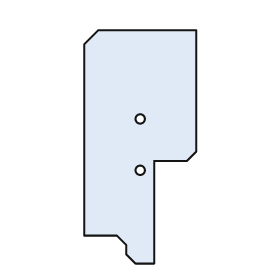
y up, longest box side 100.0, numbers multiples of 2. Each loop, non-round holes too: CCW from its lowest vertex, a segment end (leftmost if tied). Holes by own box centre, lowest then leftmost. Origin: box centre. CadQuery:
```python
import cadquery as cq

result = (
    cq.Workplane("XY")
    .moveTo(-2.0, -50.0)
    .lineTo(6.0, -50.0)
    .lineTo(6.0, -6.0)
    .lineTo(20.0, -6.0)
    .lineTo(24.0, -2.0)
    .lineTo(24.0, 50.0)
    .lineTo(-18.0, 50.0)
    .lineTo(-24.0, 44.0)
    .lineTo(-24.0, -38.0)
    .lineTo(-10.0, -38.0)
    .lineTo(-6.0, -42.0)
    .lineTo(-6.0, -46.0)
    .close()
    .moveTo(0.0, -10.0)
    .circle(2.0)
    .moveTo(0.0, 12.0)
    .circle(2.0)
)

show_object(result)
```